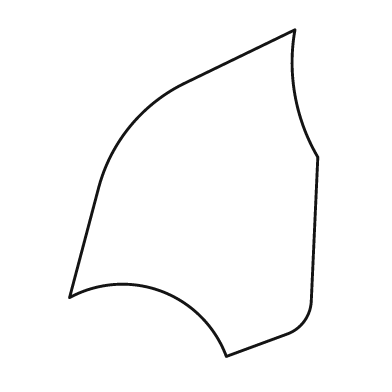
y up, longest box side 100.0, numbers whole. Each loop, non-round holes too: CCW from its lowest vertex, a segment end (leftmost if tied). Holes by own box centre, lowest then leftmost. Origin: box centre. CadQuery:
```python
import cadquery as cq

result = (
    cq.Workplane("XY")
    .moveTo(10.0, -50.0)
    .lineTo(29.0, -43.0)
    .threePointArc((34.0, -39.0), (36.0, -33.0))
    .lineTo(38.0, 11.0)
    .threePointArc((31.0, 30.0), (31.0, 50.0))
    .lineTo(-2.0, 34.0)
    .threePointArc((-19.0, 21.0), (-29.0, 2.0))
    .lineTo(-38.0, -32.0)
    .threePointArc((-10.0, -30.0), (10.0, -50.0))
    .close()
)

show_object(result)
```